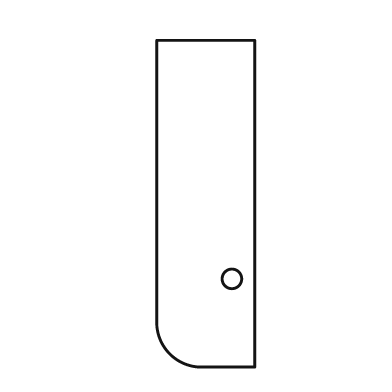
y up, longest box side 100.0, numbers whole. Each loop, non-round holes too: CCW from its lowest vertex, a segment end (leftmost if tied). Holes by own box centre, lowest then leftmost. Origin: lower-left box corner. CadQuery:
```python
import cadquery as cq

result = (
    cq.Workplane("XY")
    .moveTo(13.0, 0.0)
    .lineTo(30.0, 0.0)
    .lineTo(30.0, 100.0)
    .lineTo(0.0, 100.0)
    .lineTo(0.0, 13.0)
    .threePointArc((4.0, 4.0), (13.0, 0.0))
    .close()
    .moveTo(23.0, 27.0)
    .circle(3.0)
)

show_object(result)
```